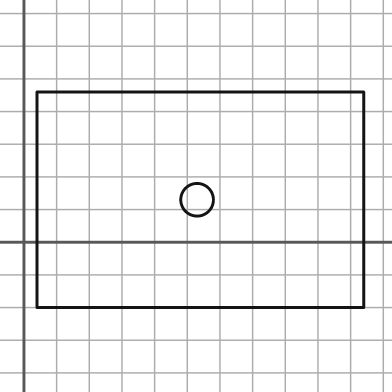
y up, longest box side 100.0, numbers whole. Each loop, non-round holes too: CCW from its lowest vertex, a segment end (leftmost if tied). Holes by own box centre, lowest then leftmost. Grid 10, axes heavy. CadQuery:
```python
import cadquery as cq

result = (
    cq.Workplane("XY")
    .moveTo(4.0, -20.0)
    .lineTo(104.0, -20.0)
    .lineTo(104.0, 46.0)
    .lineTo(4.0, 46.0)
    .close()
    .moveTo(53.0, 13.0)
    .circle(5.0)
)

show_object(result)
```